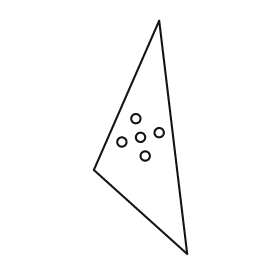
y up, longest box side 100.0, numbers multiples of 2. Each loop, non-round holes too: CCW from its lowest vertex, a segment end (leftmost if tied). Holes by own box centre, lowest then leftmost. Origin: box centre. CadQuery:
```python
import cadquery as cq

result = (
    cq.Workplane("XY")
    .moveTo(20.0, -50.0)
    .lineTo(8.0, 50.0)
    .lineTo(-20.0, -14.0)
    .close()
    .moveTo(2.0, -8.0)
    .circle(2.0)
    .moveTo(-8.0, -2.0)
    .circle(2.0)
    .moveTo(0.0, 0.0)
    .circle(2.0)
    .moveTo(8.0, 2.0)
    .circle(2.0)
    .moveTo(-2.0, 8.0)
    .circle(2.0)
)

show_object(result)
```